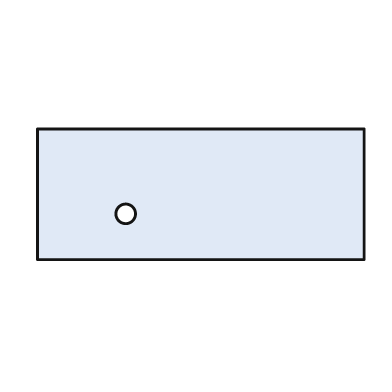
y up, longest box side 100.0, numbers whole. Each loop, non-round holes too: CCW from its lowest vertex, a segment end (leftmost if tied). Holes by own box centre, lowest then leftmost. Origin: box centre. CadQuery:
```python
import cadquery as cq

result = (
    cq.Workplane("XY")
    .moveTo(-50.0, -20.0)
    .lineTo(50.0, -20.0)
    .lineTo(50.0, 20.0)
    .lineTo(-50.0, 20.0)
    .close()
    .moveTo(-23.0, -6.0)
    .circle(3.0)
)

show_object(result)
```